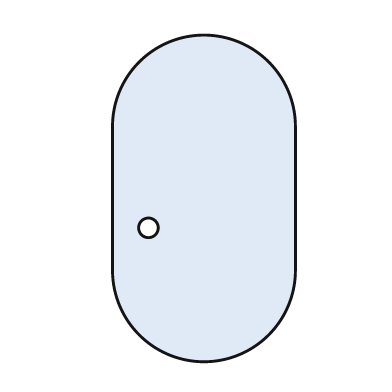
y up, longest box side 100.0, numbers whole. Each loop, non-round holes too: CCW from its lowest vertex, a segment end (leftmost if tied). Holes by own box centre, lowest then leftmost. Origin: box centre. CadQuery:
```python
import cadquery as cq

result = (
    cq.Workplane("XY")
    .moveTo(-28.0, -22.0)
    .threePointArc((0.0, -50.0), (28.0, -22.0))
    .lineTo(28.0, 22.0)
    .threePointArc((0.0, 50.0), (-28.0, 22.0))
    .close()
    .moveTo(-17.0, -9.0)
    .circle(3.0)
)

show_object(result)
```